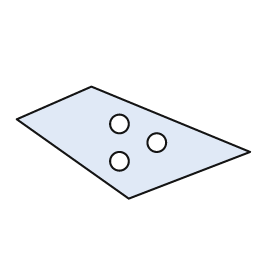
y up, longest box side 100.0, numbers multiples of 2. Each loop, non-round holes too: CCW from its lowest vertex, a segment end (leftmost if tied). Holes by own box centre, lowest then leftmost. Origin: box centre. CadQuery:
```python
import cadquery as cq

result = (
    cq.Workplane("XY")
    .moveTo(-2.0, -24.0)
    .lineTo(50.0, -4.0)
    .lineTo(-18.0, 24.0)
    .lineTo(-50.0, 10.0)
    .close()
    .moveTo(-6.0, -8.0)
    .circle(4.0)
    .moveTo(10.0, 0.0)
    .circle(4.0)
    .moveTo(-6.0, 8.0)
    .circle(4.0)
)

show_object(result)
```